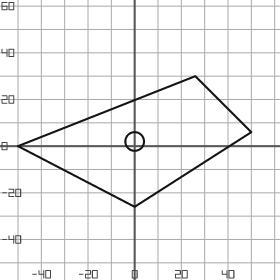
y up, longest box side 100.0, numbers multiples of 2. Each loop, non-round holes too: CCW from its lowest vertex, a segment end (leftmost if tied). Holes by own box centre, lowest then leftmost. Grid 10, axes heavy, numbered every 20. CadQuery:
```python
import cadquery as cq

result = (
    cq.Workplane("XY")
    .moveTo(0.0, -26.0)
    .lineTo(50.0, 6.0)
    .lineTo(26.0, 30.0)
    .lineTo(-50.0, 0.0)
    .close()
    .moveTo(0.0, 2.0)
    .circle(4.0)
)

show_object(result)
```